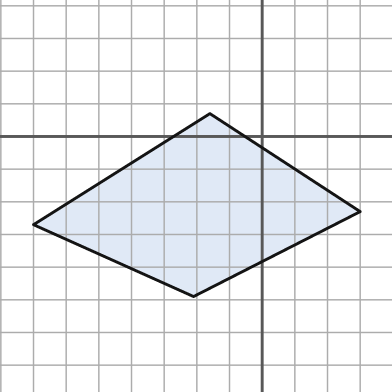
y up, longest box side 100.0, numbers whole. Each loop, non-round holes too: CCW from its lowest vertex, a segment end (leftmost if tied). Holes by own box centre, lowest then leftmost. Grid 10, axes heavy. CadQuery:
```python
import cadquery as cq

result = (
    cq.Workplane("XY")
    .moveTo(-21.0, -49.0)
    .lineTo(30.0, -23.0)
    .lineTo(-16.0, 7.0)
    .lineTo(-70.0, -27.0)
    .close()
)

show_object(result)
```